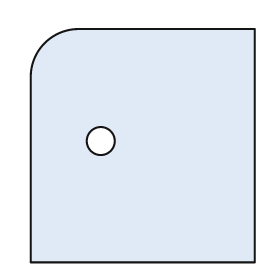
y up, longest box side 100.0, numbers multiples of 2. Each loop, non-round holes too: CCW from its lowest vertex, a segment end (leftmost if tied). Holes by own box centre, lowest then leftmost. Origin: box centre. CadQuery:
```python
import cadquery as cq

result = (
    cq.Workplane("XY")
    .moveTo(-48.0, -50.0)
    .lineTo(48.0, -50.0)
    .lineTo(48.0, 50.0)
    .lineTo(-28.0, 50.0)
    .threePointArc((-42.0, 44.0), (-48.0, 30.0))
    .close()
    .moveTo(-18.0, 2.0)
    .circle(6.0)
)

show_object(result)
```